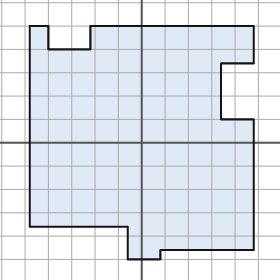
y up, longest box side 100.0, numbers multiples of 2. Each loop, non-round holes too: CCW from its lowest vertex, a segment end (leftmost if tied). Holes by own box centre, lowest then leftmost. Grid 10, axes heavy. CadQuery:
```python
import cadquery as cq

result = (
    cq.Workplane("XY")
    .moveTo(-6.0, -50.0)
    .lineTo(8.0, -50.0)
    .lineTo(8.0, -46.0)
    .lineTo(48.0, -46.0)
    .lineTo(48.0, 10.0)
    .lineTo(34.0, 10.0)
    .lineTo(34.0, 34.0)
    .lineTo(48.0, 34.0)
    .lineTo(48.0, 50.0)
    .lineTo(-22.0, 50.0)
    .lineTo(-22.0, 40.0)
    .lineTo(-40.0, 40.0)
    .lineTo(-40.0, 50.0)
    .lineTo(-48.0, 50.0)
    .lineTo(-48.0, -36.0)
    .lineTo(-6.0, -36.0)
    .close()
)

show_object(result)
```